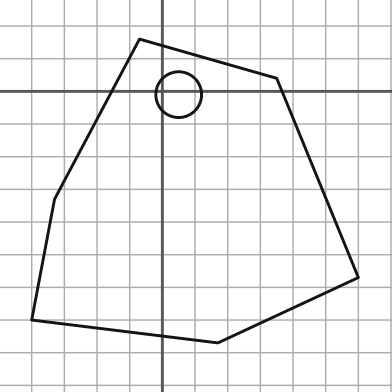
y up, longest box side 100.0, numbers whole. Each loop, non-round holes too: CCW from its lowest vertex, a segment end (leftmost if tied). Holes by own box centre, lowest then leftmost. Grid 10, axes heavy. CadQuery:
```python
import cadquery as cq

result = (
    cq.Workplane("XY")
    .moveTo(17.0, -77.0)
    .lineTo(60.0, -57.0)
    .lineTo(35.0, 4.0)
    .lineTo(-7.0, 16.0)
    .lineTo(-33.0, -33.0)
    .lineTo(-40.0, -70.0)
    .close()
    .moveTo(5.0, -1.0)
    .circle(7.0)
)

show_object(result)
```